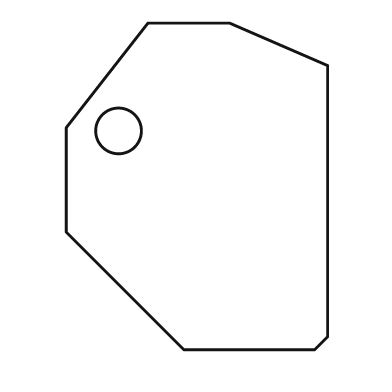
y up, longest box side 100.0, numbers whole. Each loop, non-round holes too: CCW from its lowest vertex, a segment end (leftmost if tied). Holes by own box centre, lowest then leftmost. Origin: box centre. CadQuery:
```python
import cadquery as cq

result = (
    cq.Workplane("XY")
    .moveTo(-4.0, -50.0)
    .lineTo(36.0, -50.0)
    .lineTo(40.0, -46.0)
    .lineTo(40.0, 37.0)
    .lineTo(10.0, 50.0)
    .lineTo(-15.0, 50.0)
    .lineTo(-40.0, 18.0)
    .lineTo(-40.0, -14.0)
    .close()
    .moveTo(-24.0, 17.0)
    .circle(7.0)
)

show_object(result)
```